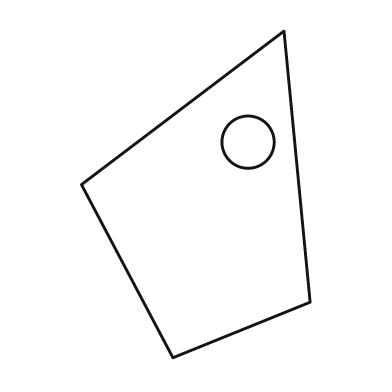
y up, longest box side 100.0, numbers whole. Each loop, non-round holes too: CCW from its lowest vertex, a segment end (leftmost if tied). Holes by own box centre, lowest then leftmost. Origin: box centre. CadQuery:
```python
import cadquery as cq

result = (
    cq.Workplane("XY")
    .moveTo(-7.0, -50.0)
    .lineTo(35.0, -33.0)
    .lineTo(27.0, 50.0)
    .lineTo(-35.0, 3.0)
    .close()
    .moveTo(16.0, 16.0)
    .circle(8.0)
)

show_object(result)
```